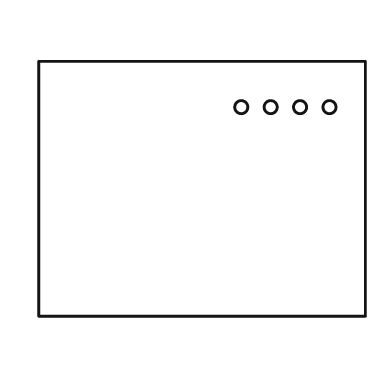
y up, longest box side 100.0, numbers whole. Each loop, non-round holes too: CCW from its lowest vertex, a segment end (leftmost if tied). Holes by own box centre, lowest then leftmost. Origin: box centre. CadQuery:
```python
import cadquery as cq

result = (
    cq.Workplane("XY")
    .moveTo(-50.0, -39.0)
    .lineTo(50.0, -39.0)
    .lineTo(50.0, 39.0)
    .lineTo(-50.0, 39.0)
    .close()
    .moveTo(12.0, 25.0)
    .circle(2.0)
    .moveTo(21.0, 25.0)
    .circle(2.0)
    .moveTo(30.0, 25.0)
    .circle(2.0)
    .moveTo(39.0, 25.0)
    .circle(2.0)
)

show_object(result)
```